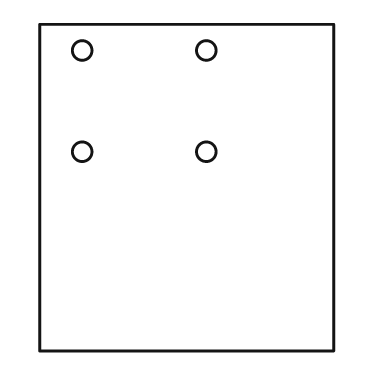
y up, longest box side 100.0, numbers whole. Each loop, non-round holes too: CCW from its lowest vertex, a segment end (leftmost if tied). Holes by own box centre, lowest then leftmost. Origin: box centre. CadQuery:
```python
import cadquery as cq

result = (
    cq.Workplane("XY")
    .moveTo(-45.0, -50.0)
    .lineTo(45.0, -50.0)
    .lineTo(45.0, 50.0)
    .lineTo(-45.0, 50.0)
    .close()
    .moveTo(-32.0, 11.0)
    .circle(3.0)
    .moveTo(6.0, 11.0)
    .circle(3.0)
    .moveTo(-32.0, 42.0)
    .circle(3.0)
    .moveTo(6.0, 42.0)
    .circle(3.0)
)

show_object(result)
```